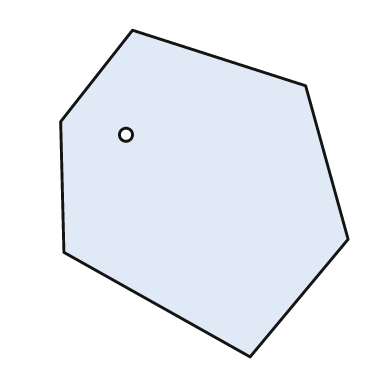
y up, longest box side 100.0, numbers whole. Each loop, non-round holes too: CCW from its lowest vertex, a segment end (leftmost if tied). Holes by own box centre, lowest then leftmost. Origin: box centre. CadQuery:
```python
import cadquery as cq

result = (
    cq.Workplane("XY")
    .moveTo(14.0, -50.0)
    .lineTo(44.0, -14.0)
    .lineTo(31.0, 33.0)
    .lineTo(-22.0, 50.0)
    .lineTo(-44.0, 22.0)
    .lineTo(-43.0, -18.0)
    .close()
    .moveTo(-24.0, 18.0)
    .circle(2.0)
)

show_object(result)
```